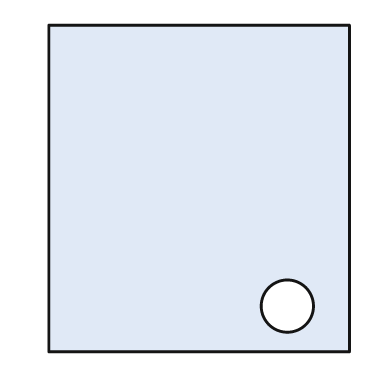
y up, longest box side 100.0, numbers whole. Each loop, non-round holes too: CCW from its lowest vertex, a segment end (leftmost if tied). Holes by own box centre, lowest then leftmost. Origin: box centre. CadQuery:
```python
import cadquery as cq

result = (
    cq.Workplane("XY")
    .moveTo(-46.0, -50.0)
    .lineTo(46.0, -50.0)
    .lineTo(46.0, 50.0)
    .lineTo(-46.0, 50.0)
    .close()
    .moveTo(27.0, -36.0)
    .circle(8.0)
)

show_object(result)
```